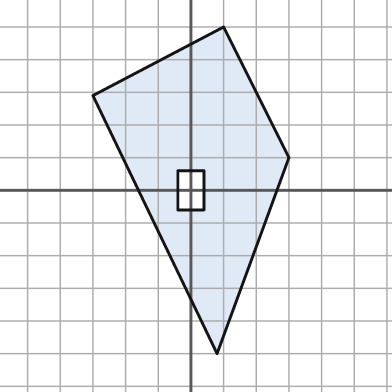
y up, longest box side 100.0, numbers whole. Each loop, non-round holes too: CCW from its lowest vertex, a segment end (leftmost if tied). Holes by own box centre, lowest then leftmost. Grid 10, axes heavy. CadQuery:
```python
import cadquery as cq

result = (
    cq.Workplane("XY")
    .moveTo(8.0, -50.0)
    .lineTo(30.0, 10.0)
    .lineTo(10.0, 50.0)
    .lineTo(-30.0, 29.0)
    .close()
    .moveTo(-4.0, -6.0)
    .lineTo(4.0, -6.0)
    .lineTo(4.0, 6.0)
    .lineTo(-4.0, 6.0)
    .close()
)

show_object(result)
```